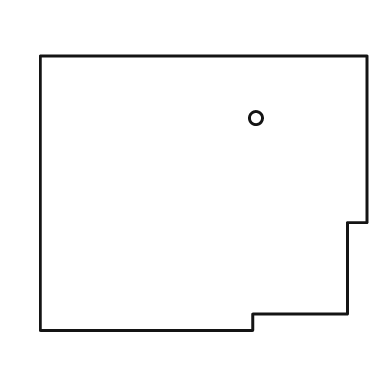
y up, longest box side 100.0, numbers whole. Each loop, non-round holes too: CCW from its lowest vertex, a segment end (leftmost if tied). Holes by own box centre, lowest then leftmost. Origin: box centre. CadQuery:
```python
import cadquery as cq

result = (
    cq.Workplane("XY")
    .moveTo(-50.0, -42.0)
    .lineTo(15.0, -42.0)
    .lineTo(15.0, -37.0)
    .lineTo(44.0, -37.0)
    .lineTo(44.0, -9.0)
    .lineTo(50.0, -9.0)
    .lineTo(50.0, 42.0)
    .lineTo(-50.0, 42.0)
    .close()
    .moveTo(16.0, 23.0)
    .circle(2.0)
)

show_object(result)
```